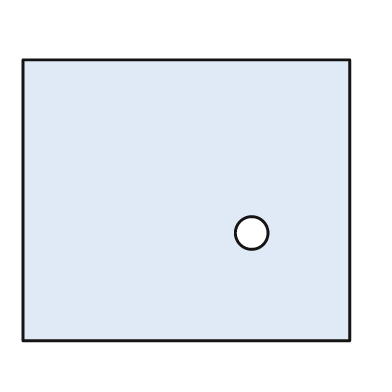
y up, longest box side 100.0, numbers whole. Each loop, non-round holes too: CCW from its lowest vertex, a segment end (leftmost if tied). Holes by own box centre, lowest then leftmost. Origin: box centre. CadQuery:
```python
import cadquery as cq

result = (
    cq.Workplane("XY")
    .moveTo(-50.0, -43.0)
    .lineTo(50.0, -43.0)
    .lineTo(50.0, 43.0)
    .lineTo(-50.0, 43.0)
    .close()
    .moveTo(20.0, -10.0)
    .circle(5.0)
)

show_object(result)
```